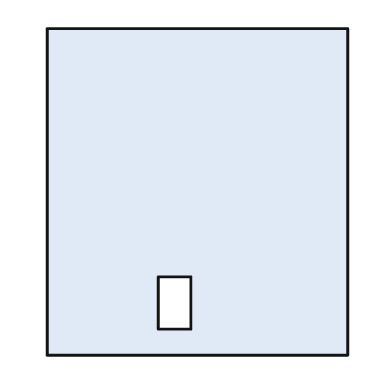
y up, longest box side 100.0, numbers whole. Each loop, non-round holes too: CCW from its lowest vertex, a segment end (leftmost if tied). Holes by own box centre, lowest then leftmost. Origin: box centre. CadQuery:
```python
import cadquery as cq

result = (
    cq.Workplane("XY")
    .moveTo(-46.0, -50.0)
    .lineTo(46.0, -50.0)
    .lineTo(46.0, 50.0)
    .lineTo(-46.0, 50.0)
    .close()
    .moveTo(-12.0, -42.0)
    .lineTo(-2.0, -42.0)
    .lineTo(-2.0, -26.0)
    .lineTo(-12.0, -26.0)
    .close()
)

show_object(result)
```